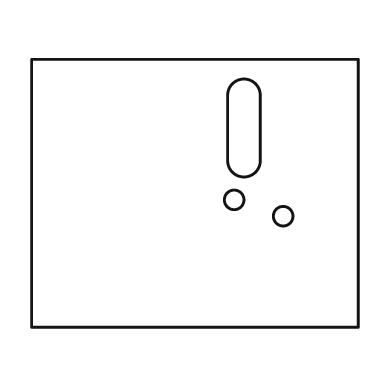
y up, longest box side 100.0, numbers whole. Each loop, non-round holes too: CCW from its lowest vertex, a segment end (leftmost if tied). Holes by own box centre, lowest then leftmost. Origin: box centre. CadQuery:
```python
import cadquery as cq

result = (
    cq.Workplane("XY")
    .moveTo(-50.0, -41.0)
    .lineTo(50.0, -41.0)
    .lineTo(50.0, 41.0)
    .lineTo(-50.0, 41.0)
    .close()
    .moveTo(27.0, -7.0)
    .circle(3.0)
    .moveTo(12.0, -2.0)
    .circle(3.0)
    .moveTo(10.0, 10.0)
    .threePointArc((15.0, 5.0), (20.0, 10.0))
    .lineTo(20.0, 30.0)
    .threePointArc((15.0, 35.0), (10.0, 30.0))
    .close()
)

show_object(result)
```